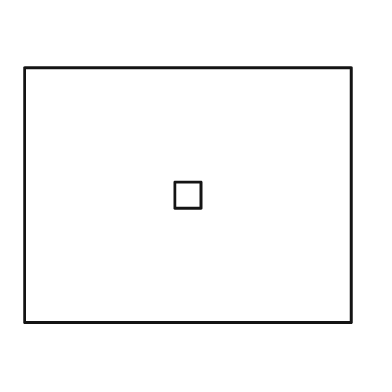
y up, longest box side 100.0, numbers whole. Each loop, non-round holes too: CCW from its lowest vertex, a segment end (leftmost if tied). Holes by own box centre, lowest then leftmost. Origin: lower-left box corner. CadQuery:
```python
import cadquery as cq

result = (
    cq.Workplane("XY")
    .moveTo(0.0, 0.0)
    .lineTo(100.0, 0.0)
    .lineTo(100.0, 78.0)
    .lineTo(0.0, 78.0)
    .close()
    .moveTo(46.0, 35.0)
    .lineTo(54.0, 35.0)
    .lineTo(54.0, 43.0)
    .lineTo(46.0, 43.0)
    .close()
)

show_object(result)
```